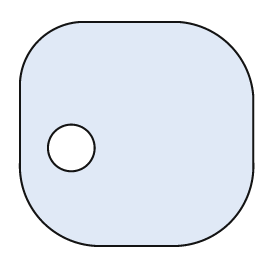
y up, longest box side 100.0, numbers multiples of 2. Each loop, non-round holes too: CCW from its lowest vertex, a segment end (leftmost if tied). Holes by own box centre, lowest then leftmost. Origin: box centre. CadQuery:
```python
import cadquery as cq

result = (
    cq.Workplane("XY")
    .moveTo(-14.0, -48.0)
    .lineTo(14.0, -48.0)
    .threePointArc((40.0, -38.0), (50.0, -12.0))
    .lineTo(50.0, 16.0)
    .threePointArc((40.0, 38.0), (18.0, 48.0))
    .lineTo(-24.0, 48.0)
    .threePointArc((-42.0, 40.0), (-50.0, 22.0))
    .lineTo(-50.0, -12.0)
    .threePointArc((-40.0, -38.0), (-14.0, -48.0))
    .close()
    .moveTo(-28.0, -6.0)
    .circle(10.0)
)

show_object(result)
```